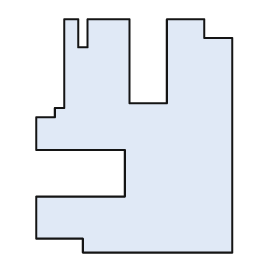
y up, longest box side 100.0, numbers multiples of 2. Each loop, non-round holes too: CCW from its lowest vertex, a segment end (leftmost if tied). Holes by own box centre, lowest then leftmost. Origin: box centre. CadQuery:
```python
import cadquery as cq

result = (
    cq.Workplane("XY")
    .moveTo(-22.0, -50.0)
    .lineTo(42.0, -50.0)
    .lineTo(42.0, 42.0)
    .lineTo(30.0, 42.0)
    .lineTo(30.0, 50.0)
    .lineTo(14.0, 50.0)
    .lineTo(14.0, 14.0)
    .lineTo(-2.0, 14.0)
    .lineTo(-2.0, 50.0)
    .lineTo(-20.0, 50.0)
    .lineTo(-20.0, 38.0)
    .lineTo(-24.0, 38.0)
    .lineTo(-24.0, 50.0)
    .lineTo(-30.0, 50.0)
    .lineTo(-30.0, 12.0)
    .lineTo(-34.0, 12.0)
    .lineTo(-34.0, 8.0)
    .lineTo(-42.0, 8.0)
    .lineTo(-42.0, -6.0)
    .lineTo(-4.0, -6.0)
    .lineTo(-4.0, -26.0)
    .lineTo(-42.0, -26.0)
    .lineTo(-42.0, -44.0)
    .lineTo(-22.0, -44.0)
    .close()
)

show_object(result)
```